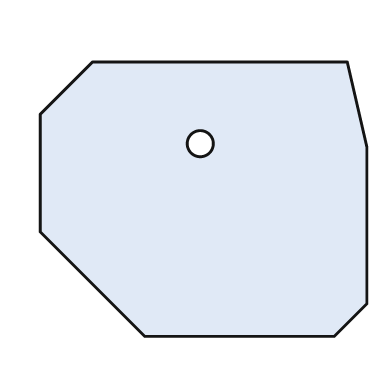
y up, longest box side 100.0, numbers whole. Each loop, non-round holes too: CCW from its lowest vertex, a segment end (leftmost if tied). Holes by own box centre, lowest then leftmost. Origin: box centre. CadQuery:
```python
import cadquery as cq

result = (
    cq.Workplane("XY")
    .moveTo(-18.0, -42.0)
    .lineTo(40.0, -42.0)
    .lineTo(50.0, -32.0)
    .lineTo(50.0, 16.0)
    .lineTo(44.0, 42.0)
    .lineTo(-34.0, 42.0)
    .lineTo(-50.0, 26.0)
    .lineTo(-50.0, -10.0)
    .close()
    .moveTo(-1.0, 17.0)
    .circle(4.0)
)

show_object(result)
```